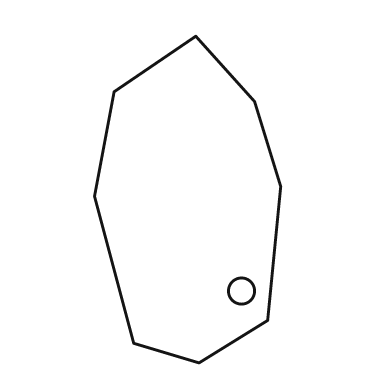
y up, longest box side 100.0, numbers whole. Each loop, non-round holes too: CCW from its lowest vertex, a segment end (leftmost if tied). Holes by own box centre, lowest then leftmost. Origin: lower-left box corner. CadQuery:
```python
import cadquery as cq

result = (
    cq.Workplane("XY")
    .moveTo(32.0, 0.0)
    .lineTo(53.0, 13.0)
    .lineTo(57.0, 54.0)
    .lineTo(49.0, 80.0)
    .lineTo(31.0, 100.0)
    .lineTo(6.0, 83.0)
    .lineTo(0.0, 51.0)
    .lineTo(12.0, 6.0)
    .close()
    .moveTo(45.0, 22.0)
    .circle(4.0)
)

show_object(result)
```